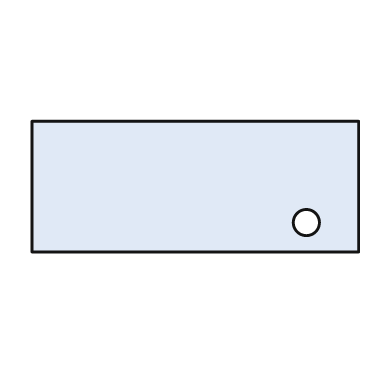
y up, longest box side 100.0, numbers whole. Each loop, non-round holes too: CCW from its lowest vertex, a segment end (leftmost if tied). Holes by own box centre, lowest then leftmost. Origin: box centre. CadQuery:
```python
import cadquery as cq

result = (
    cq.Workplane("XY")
    .moveTo(-50.0, -20.0)
    .lineTo(50.0, -20.0)
    .lineTo(50.0, 20.0)
    .lineTo(-50.0, 20.0)
    .close()
    .moveTo(34.0, -11.0)
    .circle(4.0)
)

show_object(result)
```